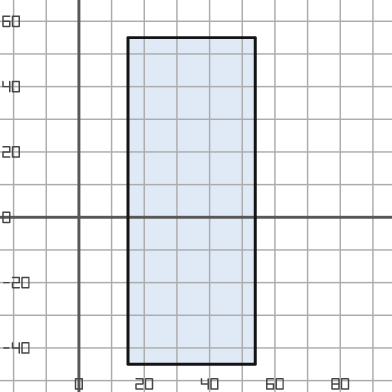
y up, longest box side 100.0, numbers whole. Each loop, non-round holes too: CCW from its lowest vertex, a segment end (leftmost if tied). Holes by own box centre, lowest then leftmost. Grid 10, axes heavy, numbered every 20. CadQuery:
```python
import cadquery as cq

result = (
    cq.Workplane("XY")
    .moveTo(15.0, -45.0)
    .lineTo(54.0, -45.0)
    .lineTo(54.0, 55.0)
    .lineTo(15.0, 55.0)
    .close()
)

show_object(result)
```